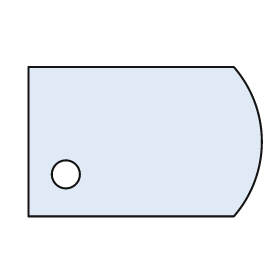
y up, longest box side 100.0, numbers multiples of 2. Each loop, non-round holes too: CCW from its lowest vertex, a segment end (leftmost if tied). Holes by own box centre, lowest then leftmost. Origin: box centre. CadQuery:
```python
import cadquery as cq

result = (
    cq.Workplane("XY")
    .moveTo(-50.0, -32.0)
    .lineTo(38.0, -32.0)
    .threePointArc((50.0, 0.0), (38.0, 32.0))
    .lineTo(-50.0, 32.0)
    .close()
    .moveTo(-34.0, -14.0)
    .circle(6.0)
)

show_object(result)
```